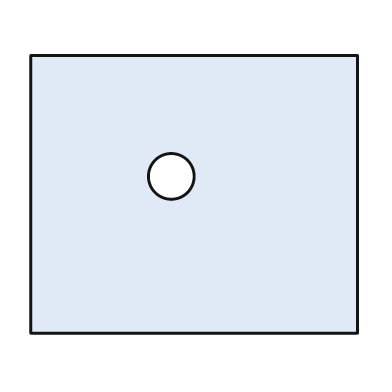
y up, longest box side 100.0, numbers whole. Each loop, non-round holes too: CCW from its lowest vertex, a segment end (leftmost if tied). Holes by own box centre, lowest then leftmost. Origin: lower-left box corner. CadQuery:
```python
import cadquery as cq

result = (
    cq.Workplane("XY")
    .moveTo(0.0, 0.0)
    .lineTo(100.0, 0.0)
    .lineTo(100.0, 85.0)
    .lineTo(0.0, 85.0)
    .close()
    .moveTo(43.0, 48.0)
    .circle(7.0)
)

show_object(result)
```